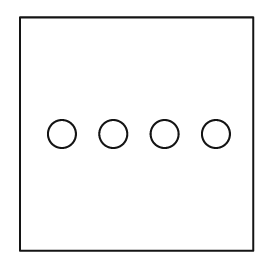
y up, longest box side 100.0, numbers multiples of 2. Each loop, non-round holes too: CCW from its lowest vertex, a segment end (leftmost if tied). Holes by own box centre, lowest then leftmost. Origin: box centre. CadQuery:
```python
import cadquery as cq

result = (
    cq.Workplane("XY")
    .moveTo(-50.0, -50.0)
    .lineTo(50.0, -50.0)
    .lineTo(50.0, 50.0)
    .lineTo(-50.0, 50.0)
    .close()
    .moveTo(-32.0, 0.0)
    .circle(6.0)
    .moveTo(-10.0, 0.0)
    .circle(6.0)
    .moveTo(12.0, 0.0)
    .circle(6.0)
    .moveTo(34.0, 0.0)
    .circle(6.0)
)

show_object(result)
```